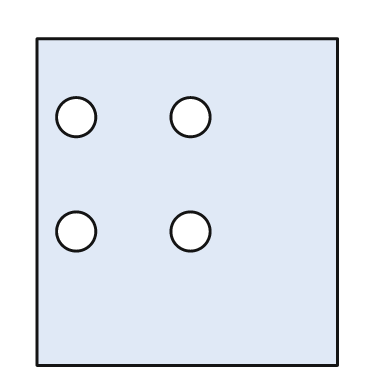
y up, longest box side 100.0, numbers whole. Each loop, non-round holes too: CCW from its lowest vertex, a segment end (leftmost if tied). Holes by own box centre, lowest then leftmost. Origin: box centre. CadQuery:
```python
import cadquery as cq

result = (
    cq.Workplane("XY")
    .moveTo(-46.0, -50.0)
    .lineTo(46.0, -50.0)
    .lineTo(46.0, 50.0)
    .lineTo(-46.0, 50.0)
    .close()
    .moveTo(-34.0, -9.0)
    .circle(6.0)
    .moveTo(1.0, -9.0)
    .circle(6.0)
    .moveTo(-34.0, 26.0)
    .circle(6.0)
    .moveTo(1.0, 26.0)
    .circle(6.0)
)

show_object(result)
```